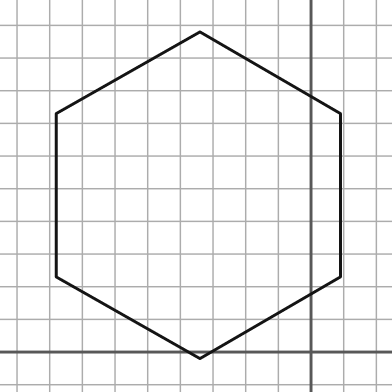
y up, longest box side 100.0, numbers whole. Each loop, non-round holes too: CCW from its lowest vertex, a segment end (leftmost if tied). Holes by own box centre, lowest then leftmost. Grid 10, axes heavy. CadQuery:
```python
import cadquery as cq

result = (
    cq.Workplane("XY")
    .moveTo(-34.0, -2.0)
    .lineTo(9.0, 23.0)
    .lineTo(9.0, 73.0)
    .lineTo(-34.0, 98.0)
    .lineTo(-78.0, 73.0)
    .lineTo(-78.0, 23.0)
    .close()
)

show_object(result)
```